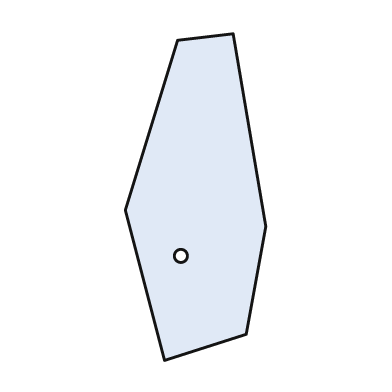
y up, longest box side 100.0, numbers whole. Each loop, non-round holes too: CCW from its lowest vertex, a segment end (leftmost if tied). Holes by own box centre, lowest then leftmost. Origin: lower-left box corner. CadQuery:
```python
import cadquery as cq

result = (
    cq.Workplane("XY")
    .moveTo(12.0, 0.0)
    .lineTo(37.0, 8.0)
    .lineTo(43.0, 41.0)
    .lineTo(33.0, 100.0)
    .lineTo(16.0, 98.0)
    .lineTo(0.0, 46.0)
    .close()
    .moveTo(17.0, 32.0)
    .circle(2.0)
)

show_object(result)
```